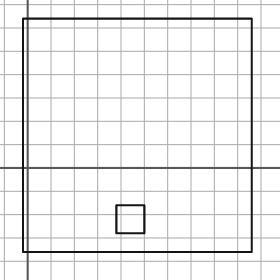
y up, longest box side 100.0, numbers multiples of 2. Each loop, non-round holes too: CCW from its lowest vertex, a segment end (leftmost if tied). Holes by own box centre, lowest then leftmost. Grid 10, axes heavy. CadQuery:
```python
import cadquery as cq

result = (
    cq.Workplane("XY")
    .moveTo(-2.0, -36.0)
    .lineTo(96.0, -36.0)
    .lineTo(96.0, 64.0)
    .lineTo(-2.0, 64.0)
    .close()
    .moveTo(38.0, -28.0)
    .lineTo(50.0, -28.0)
    .lineTo(50.0, -16.0)
    .lineTo(38.0, -16.0)
    .close()
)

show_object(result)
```